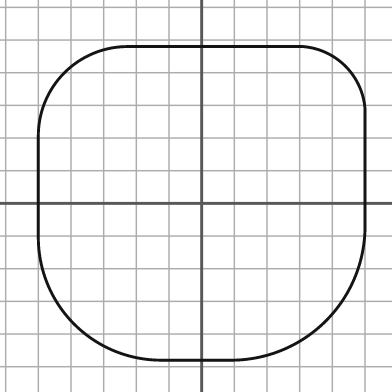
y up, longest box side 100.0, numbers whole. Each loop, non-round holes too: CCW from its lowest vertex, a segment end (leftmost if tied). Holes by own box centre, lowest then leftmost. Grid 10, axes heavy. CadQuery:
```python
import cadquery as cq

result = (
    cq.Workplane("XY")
    .moveTo(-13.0, -48.0)
    .lineTo(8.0, -48.0)
    .threePointArc((38.0, -36.0), (50.0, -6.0))
    .lineTo(50.0, 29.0)
    .threePointArc((44.0, 42.0), (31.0, 48.0))
    .lineTo(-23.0, 48.0)
    .threePointArc((-42.0, 40.0), (-50.0, 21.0))
    .lineTo(-50.0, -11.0)
    .threePointArc((-39.0, -37.0), (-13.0, -48.0))
    .close()
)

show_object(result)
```